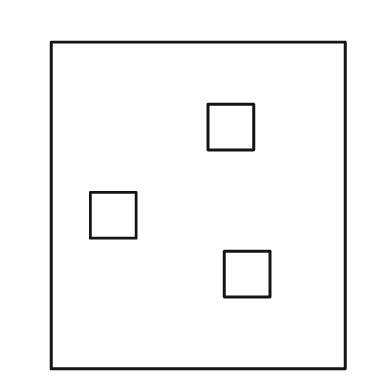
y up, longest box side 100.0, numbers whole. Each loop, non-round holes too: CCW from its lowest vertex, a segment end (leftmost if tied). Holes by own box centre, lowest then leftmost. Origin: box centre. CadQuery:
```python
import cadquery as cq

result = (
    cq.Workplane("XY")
    .moveTo(-45.0, -50.0)
    .lineTo(45.0, -50.0)
    .lineTo(45.0, 50.0)
    .lineTo(-45.0, 50.0)
    .close()
    .moveTo(8.0, -28.0)
    .lineTo(22.0, -28.0)
    .lineTo(22.0, -14.0)
    .lineTo(8.0, -14.0)
    .close()
    .moveTo(-33.0, -10.0)
    .lineTo(-19.0, -10.0)
    .lineTo(-19.0, 4.0)
    .lineTo(-33.0, 4.0)
    .close()
    .moveTo(3.0, 17.0)
    .lineTo(17.0, 17.0)
    .lineTo(17.0, 31.0)
    .lineTo(3.0, 31.0)
    .close()
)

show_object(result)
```